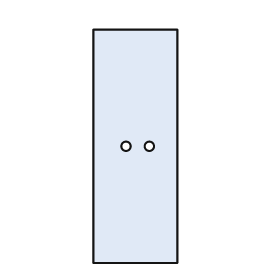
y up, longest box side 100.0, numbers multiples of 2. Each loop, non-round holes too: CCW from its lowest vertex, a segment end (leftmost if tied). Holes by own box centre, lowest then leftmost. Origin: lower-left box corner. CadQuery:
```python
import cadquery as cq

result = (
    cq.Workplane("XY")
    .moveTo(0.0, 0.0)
    .lineTo(36.0, 0.0)
    .lineTo(36.0, 100.0)
    .lineTo(0.0, 100.0)
    .close()
    .moveTo(14.0, 50.0)
    .circle(2.0)
    .moveTo(24.0, 50.0)
    .circle(2.0)
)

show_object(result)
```